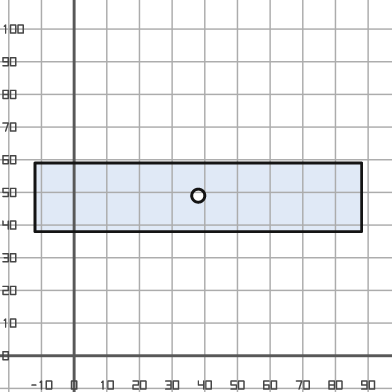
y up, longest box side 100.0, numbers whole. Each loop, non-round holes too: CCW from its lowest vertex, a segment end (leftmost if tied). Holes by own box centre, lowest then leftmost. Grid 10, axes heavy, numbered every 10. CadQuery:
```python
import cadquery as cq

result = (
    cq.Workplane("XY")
    .moveTo(-12.0, 38.0)
    .lineTo(88.0, 38.0)
    .lineTo(88.0, 59.0)
    .lineTo(-12.0, 59.0)
    .close()
    .moveTo(38.0, 49.0)
    .circle(2.0)
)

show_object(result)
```